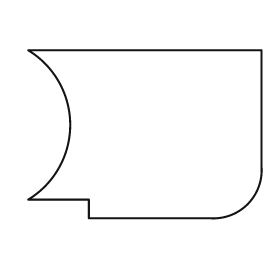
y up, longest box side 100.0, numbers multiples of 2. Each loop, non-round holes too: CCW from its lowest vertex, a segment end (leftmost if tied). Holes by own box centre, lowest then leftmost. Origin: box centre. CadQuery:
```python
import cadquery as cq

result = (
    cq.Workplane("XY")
    .moveTo(-24.0, -36.0)
    .lineTo(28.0, -36.0)
    .threePointArc((44.0, -30.0), (50.0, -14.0))
    .lineTo(50.0, 36.0)
    .lineTo(-50.0, 36.0)
    .threePointArc((-32.0, 4.0), (-50.0, -28.0))
    .lineTo(-24.0, -28.0)
    .close()
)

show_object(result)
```